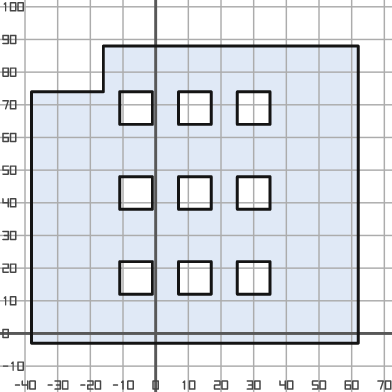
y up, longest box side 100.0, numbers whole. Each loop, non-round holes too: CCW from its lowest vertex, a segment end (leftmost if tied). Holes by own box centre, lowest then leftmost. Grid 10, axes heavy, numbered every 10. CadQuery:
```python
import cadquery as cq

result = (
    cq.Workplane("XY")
    .moveTo(-38.0, -3.0)
    .lineTo(62.0, -3.0)
    .lineTo(62.0, 88.0)
    .lineTo(-16.0, 88.0)
    .lineTo(-16.0, 74.0)
    .lineTo(-38.0, 74.0)
    .close()
    .moveTo(-11.0, 12.0)
    .lineTo(-1.0, 12.0)
    .lineTo(-1.0, 22.0)
    .lineTo(-11.0, 22.0)
    .close()
    .moveTo(7.0, 12.0)
    .lineTo(17.0, 12.0)
    .lineTo(17.0, 22.0)
    .lineTo(7.0, 22.0)
    .close()
    .moveTo(25.0, 12.0)
    .lineTo(35.0, 12.0)
    .lineTo(35.0, 22.0)
    .lineTo(25.0, 22.0)
    .close()
    .moveTo(-11.0, 38.0)
    .lineTo(-1.0, 38.0)
    .lineTo(-1.0, 48.0)
    .lineTo(-11.0, 48.0)
    .close()
    .moveTo(7.0, 38.0)
    .lineTo(17.0, 38.0)
    .lineTo(17.0, 48.0)
    .lineTo(7.0, 48.0)
    .close()
    .moveTo(25.0, 38.0)
    .lineTo(35.0, 38.0)
    .lineTo(35.0, 48.0)
    .lineTo(25.0, 48.0)
    .close()
    .moveTo(-11.0, 64.0)
    .lineTo(-1.0, 64.0)
    .lineTo(-1.0, 74.0)
    .lineTo(-11.0, 74.0)
    .close()
    .moveTo(7.0, 64.0)
    .lineTo(17.0, 64.0)
    .lineTo(17.0, 74.0)
    .lineTo(7.0, 74.0)
    .close()
    .moveTo(25.0, 64.0)
    .lineTo(35.0, 64.0)
    .lineTo(35.0, 74.0)
    .lineTo(25.0, 74.0)
    .close()
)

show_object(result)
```